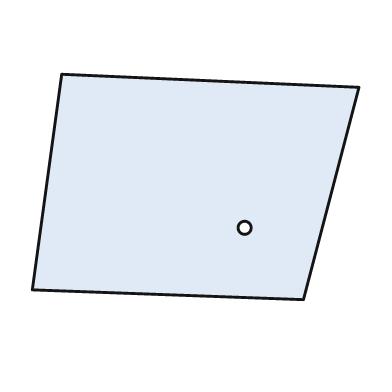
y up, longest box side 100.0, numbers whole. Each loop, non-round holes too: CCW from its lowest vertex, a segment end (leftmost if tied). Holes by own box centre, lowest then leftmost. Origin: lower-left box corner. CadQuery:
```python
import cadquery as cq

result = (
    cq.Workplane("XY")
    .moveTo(83.0, 0.0)
    .lineTo(100.0, 65.0)
    .lineTo(9.0, 69.0)
    .lineTo(0.0, 3.0)
    .close()
    .moveTo(65.0, 22.0)
    .circle(2.0)
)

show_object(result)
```